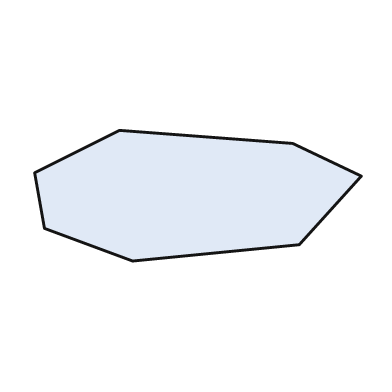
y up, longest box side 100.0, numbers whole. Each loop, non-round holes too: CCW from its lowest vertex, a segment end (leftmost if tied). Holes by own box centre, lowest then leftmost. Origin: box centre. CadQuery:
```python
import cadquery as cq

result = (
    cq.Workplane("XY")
    .moveTo(-20.0, -20.0)
    .lineTo(31.0, -15.0)
    .lineTo(50.0, 6.0)
    .lineTo(29.0, 16.0)
    .lineTo(-24.0, 20.0)
    .lineTo(-50.0, 7.0)
    .lineTo(-47.0, -10.0)
    .close()
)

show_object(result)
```